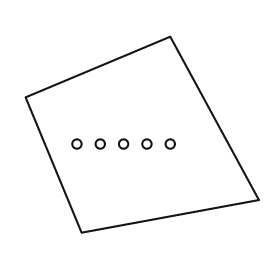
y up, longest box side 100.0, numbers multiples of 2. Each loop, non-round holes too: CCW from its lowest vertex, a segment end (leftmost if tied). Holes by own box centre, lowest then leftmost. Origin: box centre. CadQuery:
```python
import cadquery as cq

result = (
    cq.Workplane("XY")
    .moveTo(-26.0, -42.0)
    .lineTo(50.0, -28.0)
    .lineTo(12.0, 42.0)
    .lineTo(-50.0, 16.0)
    .close()
    .moveTo(-28.0, -4.0)
    .circle(2.0)
    .moveTo(-18.0, -4.0)
    .circle(2.0)
    .moveTo(-8.0, -4.0)
    .circle(2.0)
    .moveTo(2.0, -4.0)
    .circle(2.0)
    .moveTo(12.0, -4.0)
    .circle(2.0)
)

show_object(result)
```